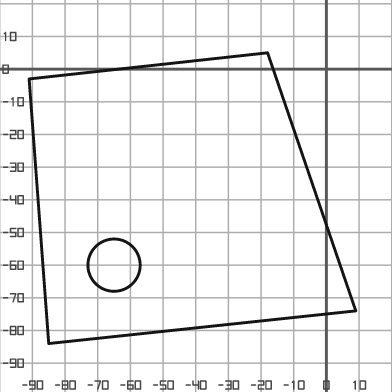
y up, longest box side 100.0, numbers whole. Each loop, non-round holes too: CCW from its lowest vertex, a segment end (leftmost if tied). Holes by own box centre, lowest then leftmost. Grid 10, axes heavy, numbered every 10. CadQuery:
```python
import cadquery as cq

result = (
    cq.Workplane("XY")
    .moveTo(-85.0, -84.0)
    .lineTo(9.0, -74.0)
    .lineTo(-18.0, 5.0)
    .lineTo(-91.0, -3.0)
    .close()
    .moveTo(-65.0, -60.0)
    .circle(8.0)
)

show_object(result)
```